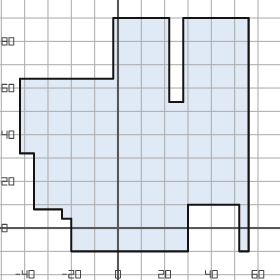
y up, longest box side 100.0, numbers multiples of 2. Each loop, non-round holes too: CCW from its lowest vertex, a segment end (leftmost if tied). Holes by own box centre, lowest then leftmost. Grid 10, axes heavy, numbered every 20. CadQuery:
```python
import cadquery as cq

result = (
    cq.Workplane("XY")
    .moveTo(-20.0, -10.0)
    .lineTo(30.0, -10.0)
    .lineTo(30.0, 10.0)
    .lineTo(52.0, 10.0)
    .lineTo(52.0, -10.0)
    .lineTo(56.0, -10.0)
    .lineTo(56.0, 90.0)
    .lineTo(28.0, 90.0)
    .lineTo(28.0, 54.0)
    .lineTo(22.0, 54.0)
    .lineTo(22.0, 90.0)
    .lineTo(-2.0, 90.0)
    .lineTo(-2.0, 64.0)
    .lineTo(-42.0, 64.0)
    .lineTo(-42.0, 32.0)
    .lineTo(-36.0, 32.0)
    .lineTo(-36.0, 8.0)
    .lineTo(-24.0, 8.0)
    .lineTo(-24.0, 4.0)
    .lineTo(-20.0, 4.0)
    .close()
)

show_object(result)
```